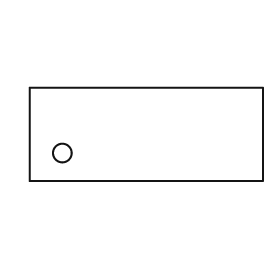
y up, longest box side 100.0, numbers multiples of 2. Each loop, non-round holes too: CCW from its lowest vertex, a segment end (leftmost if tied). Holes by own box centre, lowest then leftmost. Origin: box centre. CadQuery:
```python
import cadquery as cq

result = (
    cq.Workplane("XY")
    .moveTo(-50.0, -20.0)
    .lineTo(50.0, -20.0)
    .lineTo(50.0, 20.0)
    .lineTo(-50.0, 20.0)
    .close()
    .moveTo(-36.0, -8.0)
    .circle(4.0)
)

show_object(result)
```